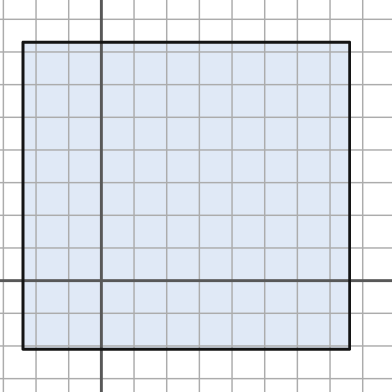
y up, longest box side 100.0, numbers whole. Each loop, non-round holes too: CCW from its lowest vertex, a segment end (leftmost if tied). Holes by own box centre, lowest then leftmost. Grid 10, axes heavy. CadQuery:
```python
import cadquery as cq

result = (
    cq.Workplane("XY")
    .moveTo(-24.0, -21.0)
    .lineTo(76.0, -21.0)
    .lineTo(76.0, 73.0)
    .lineTo(-24.0, 73.0)
    .close()
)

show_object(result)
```